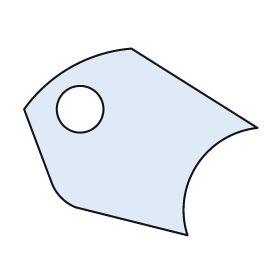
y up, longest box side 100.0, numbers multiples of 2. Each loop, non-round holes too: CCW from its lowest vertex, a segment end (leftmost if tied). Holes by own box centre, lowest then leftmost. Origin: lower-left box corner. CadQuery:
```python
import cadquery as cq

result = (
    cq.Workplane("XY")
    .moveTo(70.0, 0.0)
    .threePointArc((74.0, 30.0), (100.0, 46.0))
    .lineTo(46.0, 80.0)
    .threePointArc((20.0, 72.0), (0.0, 54.0))
    .lineTo(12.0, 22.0)
    .threePointArc((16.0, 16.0), (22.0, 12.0))
    .close()
    .moveTo(24.0, 54.0)
    .circle(10.0)
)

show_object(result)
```